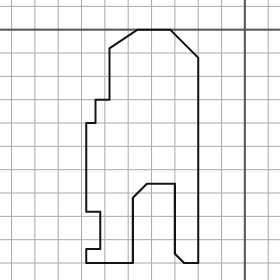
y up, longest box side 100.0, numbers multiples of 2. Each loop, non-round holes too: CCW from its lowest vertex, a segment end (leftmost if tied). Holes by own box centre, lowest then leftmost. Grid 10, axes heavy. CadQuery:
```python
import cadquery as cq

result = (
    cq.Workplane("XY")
    .moveTo(-68.0, -100.0)
    .lineTo(-48.0, -100.0)
    .lineTo(-48.0, -72.0)
    .lineTo(-42.0, -66.0)
    .lineTo(-30.0, -66.0)
    .lineTo(-30.0, -96.0)
    .lineTo(-26.0, -100.0)
    .lineTo(-20.0, -100.0)
    .lineTo(-20.0, -12.0)
    .lineTo(-32.0, 0.0)
    .lineTo(-46.0, 0.0)
    .lineTo(-58.0, -8.0)
    .lineTo(-58.0, -30.0)
    .lineTo(-64.0, -30.0)
    .lineTo(-64.0, -40.0)
    .lineTo(-68.0, -40.0)
    .lineTo(-68.0, -78.0)
    .lineTo(-62.0, -78.0)
    .lineTo(-62.0, -94.0)
    .lineTo(-68.0, -94.0)
    .close()
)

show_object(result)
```